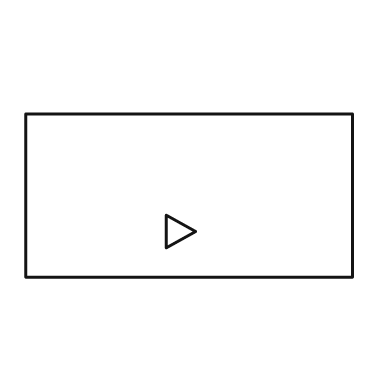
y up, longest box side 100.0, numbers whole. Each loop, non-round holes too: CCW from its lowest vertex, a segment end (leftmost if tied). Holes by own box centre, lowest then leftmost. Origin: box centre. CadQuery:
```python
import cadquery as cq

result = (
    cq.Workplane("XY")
    .moveTo(-50.0, -25.0)
    .lineTo(50.0, -25.0)
    .lineTo(50.0, 25.0)
    .lineTo(-50.0, 25.0)
    .close()
    .moveTo(-7.0, -16.0)
    .lineTo(2.0, -11.0)
    .lineTo(-7.0, -6.0)
    .close()
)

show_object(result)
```